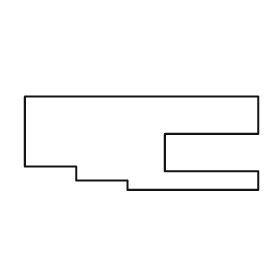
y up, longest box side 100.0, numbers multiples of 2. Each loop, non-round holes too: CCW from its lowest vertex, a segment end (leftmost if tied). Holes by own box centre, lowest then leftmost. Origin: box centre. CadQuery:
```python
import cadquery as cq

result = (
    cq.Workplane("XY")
    .moveTo(-6.0, -20.0)
    .lineTo(50.0, -20.0)
    .lineTo(50.0, -12.0)
    .lineTo(10.0, -12.0)
    .lineTo(10.0, 4.0)
    .lineTo(50.0, 4.0)
    .lineTo(50.0, 20.0)
    .lineTo(-50.0, 20.0)
    .lineTo(-50.0, -10.0)
    .lineTo(-28.0, -10.0)
    .lineTo(-28.0, -16.0)
    .lineTo(-6.0, -16.0)
    .close()
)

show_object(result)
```